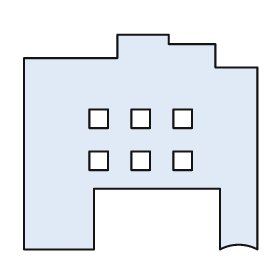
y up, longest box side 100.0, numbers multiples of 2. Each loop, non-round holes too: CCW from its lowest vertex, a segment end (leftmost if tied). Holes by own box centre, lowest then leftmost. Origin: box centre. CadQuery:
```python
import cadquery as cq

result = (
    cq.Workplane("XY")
    .moveTo(-50.0, -46.0)
    .lineTo(-20.0, -46.0)
    .lineTo(-20.0, -20.0)
    .lineTo(34.0, -20.0)
    .lineTo(34.0, -46.0)
    .threePointArc((42.0, -44.0), (50.0, -46.0))
    .lineTo(50.0, 32.0)
    .lineTo(32.0, 32.0)
    .lineTo(32.0, 42.0)
    .lineTo(12.0, 42.0)
    .lineTo(12.0, 46.0)
    .lineTo(-10.0, 46.0)
    .lineTo(-10.0, 36.0)
    .lineTo(-50.0, 36.0)
    .close()
    .moveTo(-22.0, -12.0)
    .lineTo(-14.0, -12.0)
    .lineTo(-14.0, -4.0)
    .lineTo(-22.0, -4.0)
    .close()
    .moveTo(-4.0, -12.0)
    .lineTo(4.0, -12.0)
    .lineTo(4.0, -4.0)
    .lineTo(-4.0, -4.0)
    .close()
    .moveTo(14.0, -12.0)
    .lineTo(22.0, -12.0)
    .lineTo(22.0, -4.0)
    .lineTo(14.0, -4.0)
    .close()
    .moveTo(-22.0, 6.0)
    .lineTo(-14.0, 6.0)
    .lineTo(-14.0, 14.0)
    .lineTo(-22.0, 14.0)
    .close()
    .moveTo(-4.0, 6.0)
    .lineTo(4.0, 6.0)
    .lineTo(4.0, 14.0)
    .lineTo(-4.0, 14.0)
    .close()
    .moveTo(14.0, 6.0)
    .lineTo(22.0, 6.0)
    .lineTo(22.0, 14.0)
    .lineTo(14.0, 14.0)
    .close()
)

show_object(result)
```